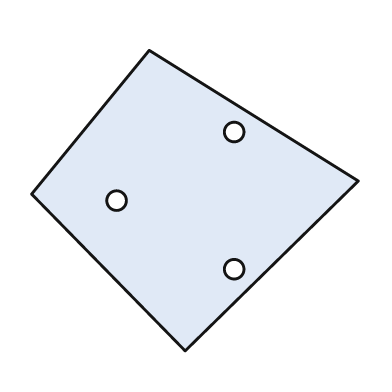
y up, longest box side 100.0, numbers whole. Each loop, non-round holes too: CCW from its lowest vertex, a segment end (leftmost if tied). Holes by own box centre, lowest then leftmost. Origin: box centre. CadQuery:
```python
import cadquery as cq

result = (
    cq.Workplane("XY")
    .moveTo(-3.0, -46.0)
    .lineTo(50.0, 6.0)
    .lineTo(-14.0, 46.0)
    .lineTo(-50.0, 2.0)
    .close()
    .moveTo(12.0, -21.0)
    .circle(3.0)
    .moveTo(-24.0, 0.0)
    .circle(3.0)
    .moveTo(12.0, 21.0)
    .circle(3.0)
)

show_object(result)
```